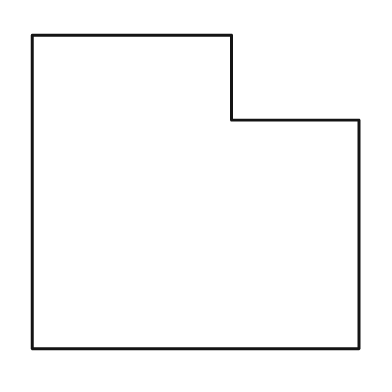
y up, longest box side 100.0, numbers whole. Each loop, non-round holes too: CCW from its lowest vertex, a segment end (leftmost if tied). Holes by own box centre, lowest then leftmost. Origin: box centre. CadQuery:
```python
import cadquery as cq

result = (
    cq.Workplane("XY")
    .moveTo(-50.0, -48.0)
    .lineTo(50.0, -48.0)
    .lineTo(50.0, 22.0)
    .lineTo(11.0, 22.0)
    .lineTo(11.0, 48.0)
    .lineTo(-50.0, 48.0)
    .close()
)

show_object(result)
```